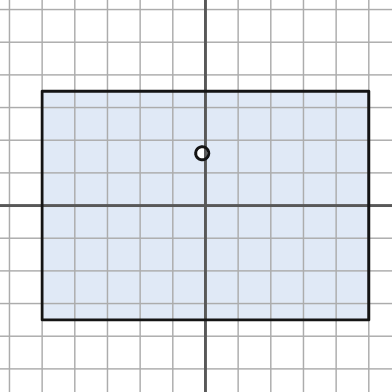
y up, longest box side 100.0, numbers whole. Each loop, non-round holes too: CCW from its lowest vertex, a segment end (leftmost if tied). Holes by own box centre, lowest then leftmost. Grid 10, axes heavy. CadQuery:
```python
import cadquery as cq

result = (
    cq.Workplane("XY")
    .moveTo(-50.0, -35.0)
    .lineTo(50.0, -35.0)
    .lineTo(50.0, 35.0)
    .lineTo(-50.0, 35.0)
    .close()
    .moveTo(-1.0, 16.0)
    .circle(2.0)
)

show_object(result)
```